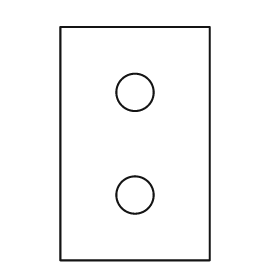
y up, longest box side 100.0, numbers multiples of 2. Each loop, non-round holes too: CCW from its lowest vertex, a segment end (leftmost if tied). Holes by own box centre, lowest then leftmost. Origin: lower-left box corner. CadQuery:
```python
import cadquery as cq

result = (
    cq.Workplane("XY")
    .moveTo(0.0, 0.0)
    .lineTo(64.0, 0.0)
    .lineTo(64.0, 100.0)
    .lineTo(0.0, 100.0)
    .close()
    .moveTo(32.0, 28.0)
    .circle(8.0)
    .moveTo(32.0, 72.0)
    .circle(8.0)
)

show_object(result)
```